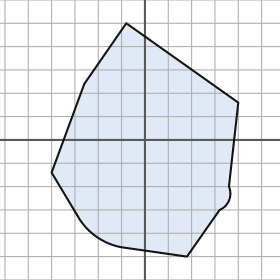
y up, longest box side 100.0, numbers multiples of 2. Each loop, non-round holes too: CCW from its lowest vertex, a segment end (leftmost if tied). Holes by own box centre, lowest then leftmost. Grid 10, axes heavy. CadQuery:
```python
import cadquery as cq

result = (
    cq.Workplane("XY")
    .moveTo(18.0, -50.0)
    .lineTo(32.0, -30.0)
    .threePointArc((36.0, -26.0), (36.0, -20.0))
    .lineTo(40.0, 16.0)
    .lineTo(-8.0, 50.0)
    .lineTo(-26.0, 24.0)
    .lineTo(-40.0, -14.0)
    .lineTo(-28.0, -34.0)
    .threePointArc((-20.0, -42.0), (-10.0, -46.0))
    .close()
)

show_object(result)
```